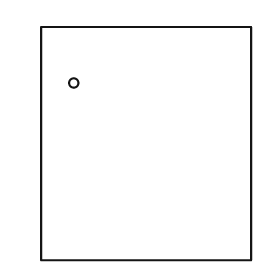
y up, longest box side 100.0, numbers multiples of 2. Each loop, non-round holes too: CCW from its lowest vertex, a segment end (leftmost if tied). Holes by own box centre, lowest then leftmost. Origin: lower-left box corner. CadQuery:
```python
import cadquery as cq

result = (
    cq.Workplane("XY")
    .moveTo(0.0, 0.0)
    .lineTo(90.0, 0.0)
    .lineTo(90.0, 100.0)
    .lineTo(0.0, 100.0)
    .close()
    .moveTo(14.0, 76.0)
    .circle(2.0)
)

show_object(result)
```